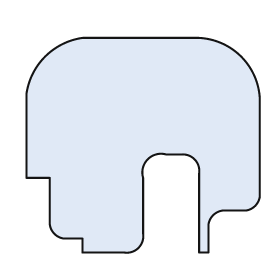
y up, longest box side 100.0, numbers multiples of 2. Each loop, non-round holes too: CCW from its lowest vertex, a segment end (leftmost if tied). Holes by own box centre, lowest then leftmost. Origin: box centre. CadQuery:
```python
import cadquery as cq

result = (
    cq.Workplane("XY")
    .moveTo(-26.0, -46.0)
    .lineTo(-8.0, -46.0)
    .threePointArc((-2.0, -44.0), (0.0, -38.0))
    .lineTo(0.0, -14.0)
    .threePointArc((2.0, -6.0), (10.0, -4.0))
    .lineTo(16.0, -4.0)
    .threePointArc((22.0, -6.0), (24.0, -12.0))
    .lineTo(24.0, -46.0)
    .lineTo(28.0, -46.0)
    .lineTo(28.0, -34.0)
    .threePointArc((30.0, -30.0), (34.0, -28.0))
    .lineTo(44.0, -28.0)
    .threePointArc((48.0, -26.0), (50.0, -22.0))
    .lineTo(50.0, 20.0)
    .threePointArc((42.0, 38.0), (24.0, 46.0))
    .lineTo(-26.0, 46.0)
    .threePointArc((-42.0, 38.0), (-50.0, 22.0))
    .lineTo(-50.0, -14.0)
    .lineTo(-40.0, -14.0)
    .lineTo(-40.0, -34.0)
    .threePointArc((-38.0, -38.0), (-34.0, -40.0))
    .lineTo(-26.0, -40.0)
    .close()
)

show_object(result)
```